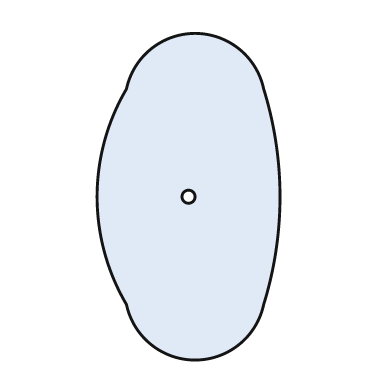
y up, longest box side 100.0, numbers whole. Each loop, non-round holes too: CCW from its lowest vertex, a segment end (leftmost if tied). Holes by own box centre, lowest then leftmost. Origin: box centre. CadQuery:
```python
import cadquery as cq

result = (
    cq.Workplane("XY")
    .moveTo(-19.0, -33.0)
    .threePointArc((2.0, -50.0), (23.0, -33.0))
    .threePointArc((28.0, 0.0), (23.0, 33.0))
    .threePointArc((2.0, 50.0), (-19.0, 33.0))
    .threePointArc((-28.0, 0.0), (-19.0, -33.0))
    .close()
    .moveTo(0.0, 0.0)
    .circle(2.0)
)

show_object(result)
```